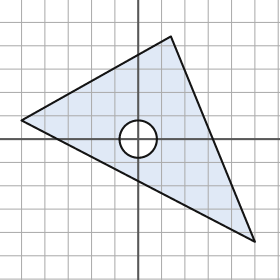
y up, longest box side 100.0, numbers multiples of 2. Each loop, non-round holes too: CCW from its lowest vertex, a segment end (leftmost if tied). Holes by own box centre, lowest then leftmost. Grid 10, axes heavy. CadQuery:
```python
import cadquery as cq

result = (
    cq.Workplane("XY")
    .moveTo(50.0, -44.0)
    .lineTo(14.0, 44.0)
    .lineTo(-50.0, 8.0)
    .close()
    .moveTo(0.0, 0.0)
    .circle(8.0)
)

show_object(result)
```